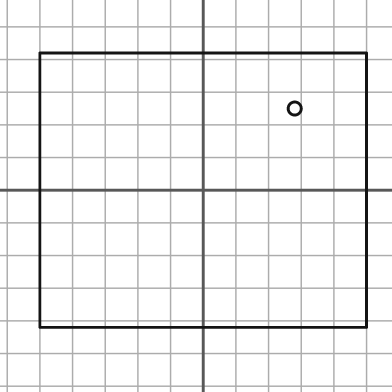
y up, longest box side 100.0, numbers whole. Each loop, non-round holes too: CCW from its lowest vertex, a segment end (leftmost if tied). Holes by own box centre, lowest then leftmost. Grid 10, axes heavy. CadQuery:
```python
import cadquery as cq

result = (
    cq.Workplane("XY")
    .moveTo(-50.0, -42.0)
    .lineTo(50.0, -42.0)
    .lineTo(50.0, 42.0)
    .lineTo(-50.0, 42.0)
    .close()
    .moveTo(28.0, 25.0)
    .circle(2.0)
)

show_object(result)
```